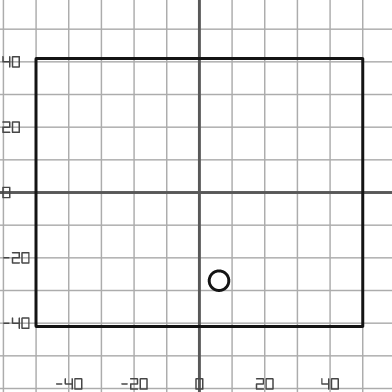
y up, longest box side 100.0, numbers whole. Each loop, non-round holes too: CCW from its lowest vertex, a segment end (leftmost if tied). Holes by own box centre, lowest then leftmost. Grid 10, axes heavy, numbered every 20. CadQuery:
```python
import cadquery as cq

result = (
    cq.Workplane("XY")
    .moveTo(-50.0, -41.0)
    .lineTo(50.0, -41.0)
    .lineTo(50.0, 41.0)
    .lineTo(-50.0, 41.0)
    .close()
    .moveTo(6.0, -27.0)
    .circle(3.0)
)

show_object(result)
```